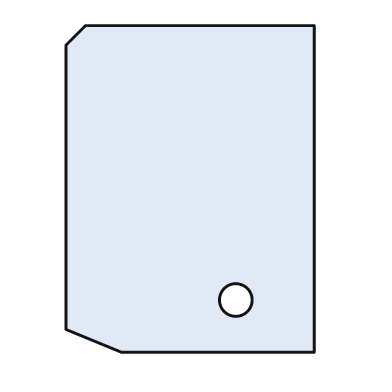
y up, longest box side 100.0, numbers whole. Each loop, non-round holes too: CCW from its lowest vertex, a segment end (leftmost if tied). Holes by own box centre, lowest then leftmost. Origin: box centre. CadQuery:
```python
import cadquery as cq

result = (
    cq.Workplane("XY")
    .moveTo(-21.0, -50.0)
    .lineTo(38.0, -50.0)
    .lineTo(38.0, 50.0)
    .lineTo(-32.0, 50.0)
    .lineTo(-38.0, 44.0)
    .lineTo(-38.0, -43.0)
    .close()
    .moveTo(14.0, -34.0)
    .circle(5.0)
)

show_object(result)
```